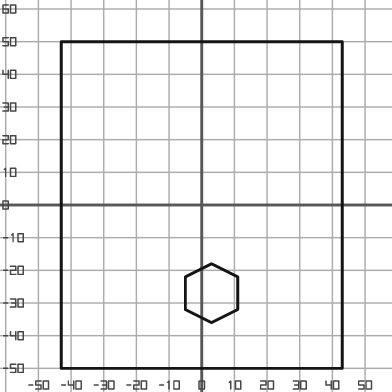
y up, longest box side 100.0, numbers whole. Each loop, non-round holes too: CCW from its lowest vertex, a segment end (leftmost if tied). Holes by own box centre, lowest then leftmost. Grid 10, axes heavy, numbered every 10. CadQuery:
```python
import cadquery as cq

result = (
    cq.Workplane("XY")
    .moveTo(-43.0, -50.0)
    .lineTo(43.0, -50.0)
    .lineTo(43.0, 50.0)
    .lineTo(-43.0, 50.0)
    .close()
    .moveTo(3.0, -36.0)
    .lineTo(11.0, -32.0)
    .lineTo(11.0, -22.0)
    .lineTo(3.0, -18.0)
    .lineTo(-5.0, -22.0)
    .lineTo(-5.0, -32.0)
    .close()
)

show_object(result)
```